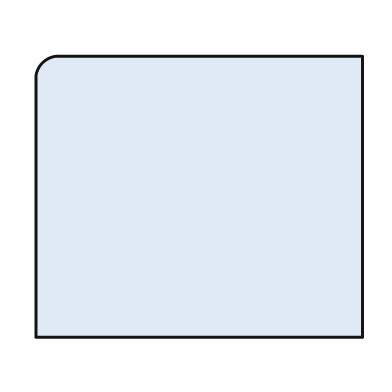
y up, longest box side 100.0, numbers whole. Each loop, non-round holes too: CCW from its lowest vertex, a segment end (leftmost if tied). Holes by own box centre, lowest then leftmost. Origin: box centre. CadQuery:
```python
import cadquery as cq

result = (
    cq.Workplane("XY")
    .moveTo(-50.0, -43.0)
    .lineTo(50.0, -43.0)
    .lineTo(50.0, 43.0)
    .lineTo(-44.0, 43.0)
    .threePointArc((-48.0, 41.0), (-50.0, 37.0))
    .close()
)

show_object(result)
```